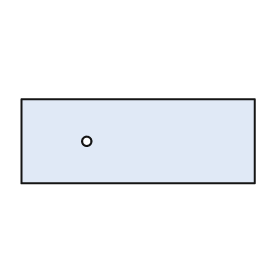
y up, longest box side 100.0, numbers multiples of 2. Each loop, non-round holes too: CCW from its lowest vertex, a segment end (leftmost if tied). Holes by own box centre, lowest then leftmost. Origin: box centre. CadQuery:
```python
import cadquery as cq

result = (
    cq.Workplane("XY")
    .moveTo(-50.0, -18.0)
    .lineTo(50.0, -18.0)
    .lineTo(50.0, 18.0)
    .lineTo(-50.0, 18.0)
    .close()
    .moveTo(-22.0, 0.0)
    .circle(2.0)
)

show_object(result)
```